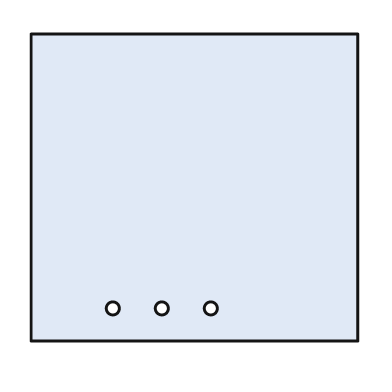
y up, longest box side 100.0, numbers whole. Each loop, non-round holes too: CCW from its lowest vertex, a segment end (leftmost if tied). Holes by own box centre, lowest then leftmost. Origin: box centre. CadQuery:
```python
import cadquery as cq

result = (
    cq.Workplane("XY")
    .moveTo(-50.0, -47.0)
    .lineTo(50.0, -47.0)
    .lineTo(50.0, 47.0)
    .lineTo(-50.0, 47.0)
    .close()
    .moveTo(-25.0, -37.0)
    .circle(2.0)
    .moveTo(-10.0, -37.0)
    .circle(2.0)
    .moveTo(5.0, -37.0)
    .circle(2.0)
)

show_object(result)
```